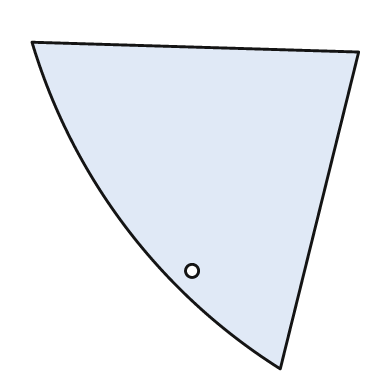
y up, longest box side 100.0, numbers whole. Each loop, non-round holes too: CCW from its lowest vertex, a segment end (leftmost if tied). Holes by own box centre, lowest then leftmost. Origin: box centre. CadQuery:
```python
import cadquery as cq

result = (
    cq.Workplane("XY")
    .moveTo(26.0, -50.0)
    .lineTo(50.0, 47.0)
    .lineTo(-50.0, 50.0)
    .threePointArc((-21.0, -7.0), (26.0, -50.0))
    .close()
    .moveTo(-1.0, -20.0)
    .circle(2.0)
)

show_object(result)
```